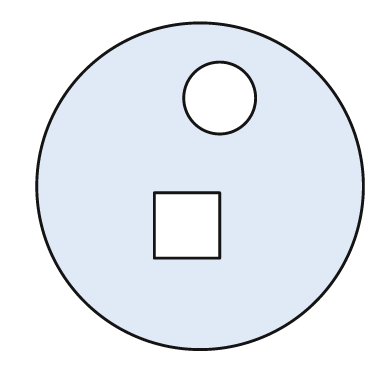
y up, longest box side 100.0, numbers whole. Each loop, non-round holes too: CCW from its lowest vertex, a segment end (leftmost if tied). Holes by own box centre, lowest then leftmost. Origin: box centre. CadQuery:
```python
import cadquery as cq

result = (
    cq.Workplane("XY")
    .moveTo(0.0, 0.0)
    .circle(50.0)
    .moveTo(-14.0, -22.0)
    .lineTo(6.0, -22.0)
    .lineTo(6.0, -2.0)
    .lineTo(-14.0, -2.0)
    .close()
    .moveTo(6.0, 27.0)
    .circle(11.0)
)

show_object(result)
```